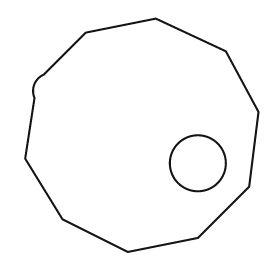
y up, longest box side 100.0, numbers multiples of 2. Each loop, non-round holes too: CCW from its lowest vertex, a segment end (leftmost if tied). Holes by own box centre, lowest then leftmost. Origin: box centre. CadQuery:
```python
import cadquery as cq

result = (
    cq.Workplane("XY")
    .moveTo(-6.0, -50.0)
    .lineTo(24.0, -44.0)
    .lineTo(46.0, -22.0)
    .lineTo(50.0, 10.0)
    .lineTo(36.0, 36.0)
    .lineTo(6.0, 50.0)
    .lineTo(-24.0, 44.0)
    .lineTo(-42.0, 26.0)
    .threePointArc((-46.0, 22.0), (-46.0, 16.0))
    .lineTo(-50.0, -10.0)
    .lineTo(-34.0, -36.0)
    .close()
    .moveTo(24.0, -12.0)
    .circle(12.0)
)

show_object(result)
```